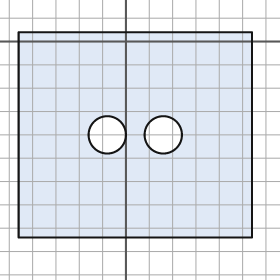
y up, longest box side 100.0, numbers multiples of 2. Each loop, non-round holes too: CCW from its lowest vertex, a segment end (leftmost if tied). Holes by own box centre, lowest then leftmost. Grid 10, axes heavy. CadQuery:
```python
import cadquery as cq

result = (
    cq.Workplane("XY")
    .moveTo(-46.0, -84.0)
    .lineTo(54.0, -84.0)
    .lineTo(54.0, 4.0)
    .lineTo(-46.0, 4.0)
    .close()
    .moveTo(-8.0, -40.0)
    .circle(8.0)
    .moveTo(16.0, -40.0)
    .circle(8.0)
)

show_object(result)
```